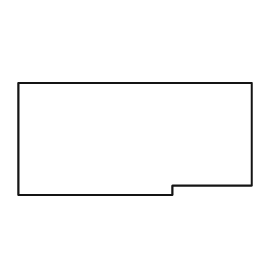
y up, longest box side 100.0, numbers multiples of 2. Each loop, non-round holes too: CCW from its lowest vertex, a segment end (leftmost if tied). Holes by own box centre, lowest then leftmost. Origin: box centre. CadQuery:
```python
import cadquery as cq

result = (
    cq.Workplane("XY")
    .moveTo(-50.0, -24.0)
    .lineTo(16.0, -24.0)
    .lineTo(16.0, -20.0)
    .lineTo(50.0, -20.0)
    .lineTo(50.0, 24.0)
    .lineTo(-50.0, 24.0)
    .close()
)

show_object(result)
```